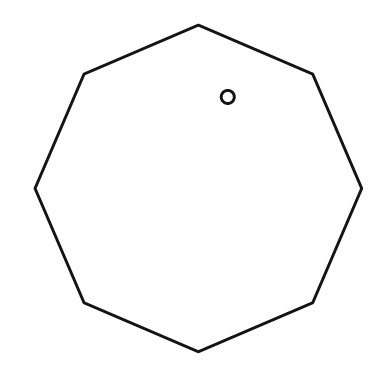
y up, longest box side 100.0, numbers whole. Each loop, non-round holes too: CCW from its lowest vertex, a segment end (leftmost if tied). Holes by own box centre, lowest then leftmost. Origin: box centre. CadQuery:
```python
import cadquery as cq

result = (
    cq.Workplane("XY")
    .moveTo(0.0, -50.0)
    .lineTo(35.0, -35.0)
    .lineTo(50.0, 0.0)
    .lineTo(35.0, 35.0)
    .lineTo(0.0, 50.0)
    .lineTo(-35.0, 35.0)
    .lineTo(-50.0, 0.0)
    .lineTo(-35.0, -35.0)
    .close()
    .moveTo(9.0, 28.0)
    .circle(2.0)
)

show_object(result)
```